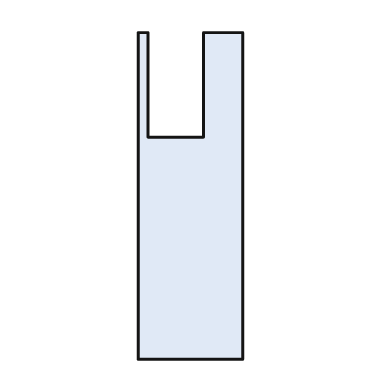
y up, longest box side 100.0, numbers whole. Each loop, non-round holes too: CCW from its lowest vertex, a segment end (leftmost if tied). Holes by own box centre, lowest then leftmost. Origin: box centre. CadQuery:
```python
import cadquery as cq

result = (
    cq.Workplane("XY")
    .moveTo(-16.0, -50.0)
    .lineTo(16.0, -50.0)
    .lineTo(16.0, 50.0)
    .lineTo(4.0, 50.0)
    .lineTo(4.0, 18.0)
    .lineTo(-13.0, 18.0)
    .lineTo(-13.0, 50.0)
    .lineTo(-16.0, 50.0)
    .close()
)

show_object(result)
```